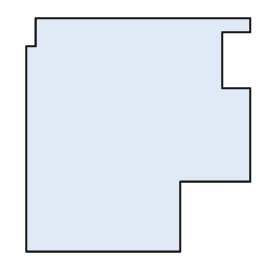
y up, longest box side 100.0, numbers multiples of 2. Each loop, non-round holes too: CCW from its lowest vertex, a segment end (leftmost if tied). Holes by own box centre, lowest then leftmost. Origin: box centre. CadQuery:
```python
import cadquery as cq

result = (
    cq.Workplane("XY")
    .moveTo(-48.0, -50.0)
    .lineTo(18.0, -50.0)
    .lineTo(18.0, -20.0)
    .lineTo(48.0, -20.0)
    .lineTo(48.0, 20.0)
    .lineTo(36.0, 20.0)
    .lineTo(36.0, 44.0)
    .lineTo(48.0, 44.0)
    .lineTo(48.0, 50.0)
    .lineTo(-44.0, 50.0)
    .lineTo(-44.0, 38.0)
    .lineTo(-48.0, 38.0)
    .close()
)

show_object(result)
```